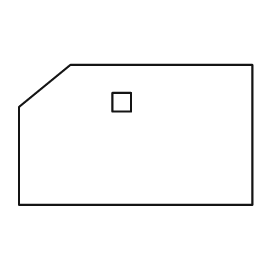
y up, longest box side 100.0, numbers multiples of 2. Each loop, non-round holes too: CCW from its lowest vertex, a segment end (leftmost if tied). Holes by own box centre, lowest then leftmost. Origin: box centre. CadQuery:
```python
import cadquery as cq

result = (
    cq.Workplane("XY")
    .moveTo(-50.0, -30.0)
    .lineTo(50.0, -30.0)
    .lineTo(50.0, 30.0)
    .lineTo(-28.0, 30.0)
    .lineTo(-50.0, 12.0)
    .close()
    .moveTo(-10.0, 10.0)
    .lineTo(-2.0, 10.0)
    .lineTo(-2.0, 18.0)
    .lineTo(-10.0, 18.0)
    .close()
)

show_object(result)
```